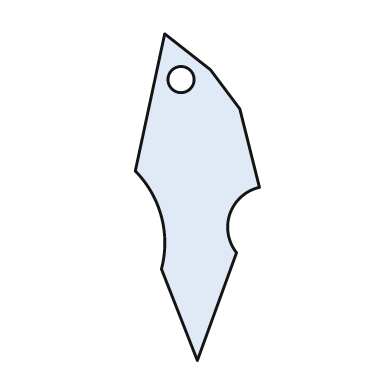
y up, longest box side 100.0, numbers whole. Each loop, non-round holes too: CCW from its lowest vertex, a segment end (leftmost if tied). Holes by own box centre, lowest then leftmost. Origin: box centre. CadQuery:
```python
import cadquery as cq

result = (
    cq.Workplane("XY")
    .moveTo(0.0, -50.0)
    .lineTo(12.0, -17.0)
    .threePointArc((10.0, -5.0), (19.0, 3.0))
    .lineTo(13.0, 27.0)
    .lineTo(4.0, 39.0)
    .lineTo(-10.0, 50.0)
    .lineTo(-19.0, 8.0)
    .threePointArc((-11.0, -6.0), (-11.0, -22.0))
    .close()
    .moveTo(-5.0, 36.0)
    .circle(4.0)
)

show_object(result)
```